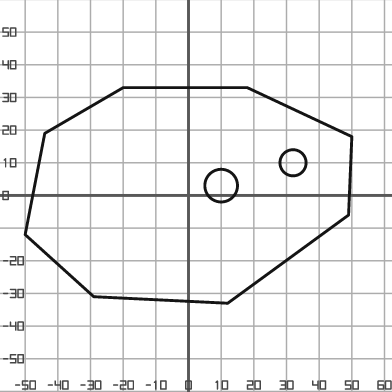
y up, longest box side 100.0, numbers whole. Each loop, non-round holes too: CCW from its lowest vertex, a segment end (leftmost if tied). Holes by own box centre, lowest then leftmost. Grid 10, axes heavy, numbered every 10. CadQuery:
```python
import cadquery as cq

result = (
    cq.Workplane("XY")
    .moveTo(12.0, -33.0)
    .lineTo(49.0, -6.0)
    .lineTo(50.0, 18.0)
    .lineTo(18.0, 33.0)
    .lineTo(-20.0, 33.0)
    .lineTo(-44.0, 19.0)
    .lineTo(-50.0, -12.0)
    .lineTo(-29.0, -31.0)
    .close()
    .moveTo(10.0, 3.0)
    .circle(5.0)
    .moveTo(32.0, 10.0)
    .circle(4.0)
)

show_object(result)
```